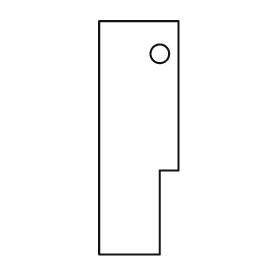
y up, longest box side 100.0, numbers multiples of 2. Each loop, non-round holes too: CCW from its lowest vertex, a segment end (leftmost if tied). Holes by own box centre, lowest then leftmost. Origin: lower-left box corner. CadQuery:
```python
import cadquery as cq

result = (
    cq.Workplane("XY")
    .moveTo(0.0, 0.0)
    .lineTo(26.0, 0.0)
    .lineTo(26.0, 36.0)
    .lineTo(34.0, 36.0)
    .lineTo(34.0, 100.0)
    .lineTo(0.0, 100.0)
    .close()
    .moveTo(26.0, 86.0)
    .circle(4.0)
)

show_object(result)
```